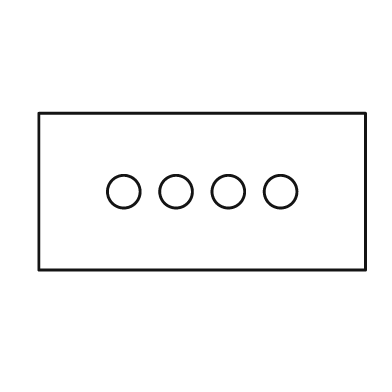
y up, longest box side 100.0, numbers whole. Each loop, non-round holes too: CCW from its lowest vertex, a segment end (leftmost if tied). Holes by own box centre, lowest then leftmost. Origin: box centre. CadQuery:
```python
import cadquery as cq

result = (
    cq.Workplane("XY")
    .moveTo(-50.0, -24.0)
    .lineTo(50.0, -24.0)
    .lineTo(50.0, 24.0)
    .lineTo(-50.0, 24.0)
    .close()
    .moveTo(-24.0, 0.0)
    .circle(5.0)
    .moveTo(-8.0, 0.0)
    .circle(5.0)
    .moveTo(8.0, 0.0)
    .circle(5.0)
    .moveTo(24.0, 0.0)
    .circle(5.0)
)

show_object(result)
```